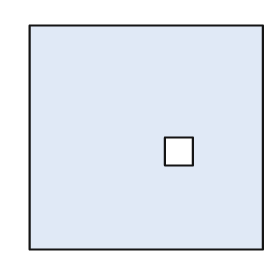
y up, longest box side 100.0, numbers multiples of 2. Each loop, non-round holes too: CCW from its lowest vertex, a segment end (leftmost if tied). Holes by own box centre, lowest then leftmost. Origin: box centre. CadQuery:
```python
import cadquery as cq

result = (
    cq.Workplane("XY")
    .moveTo(-50.0, -48.0)
    .lineTo(50.0, -48.0)
    .lineTo(50.0, 48.0)
    .lineTo(-50.0, 48.0)
    .close()
    .moveTo(8.0, -12.0)
    .lineTo(20.0, -12.0)
    .lineTo(20.0, 0.0)
    .lineTo(8.0, 0.0)
    .close()
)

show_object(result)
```